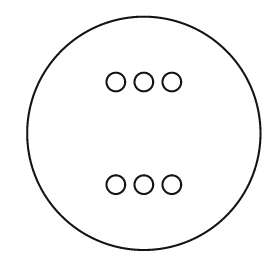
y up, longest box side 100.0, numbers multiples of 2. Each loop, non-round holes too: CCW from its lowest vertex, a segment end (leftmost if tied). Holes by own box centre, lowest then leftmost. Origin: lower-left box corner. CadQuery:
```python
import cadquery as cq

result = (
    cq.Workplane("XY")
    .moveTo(50.0, 50.0)
    .circle(50.0)
    .moveTo(38.0, 28.0)
    .circle(4.0)
    .moveTo(50.0, 28.0)
    .circle(4.0)
    .moveTo(62.0, 28.0)
    .circle(4.0)
    .moveTo(38.0, 72.0)
    .circle(4.0)
    .moveTo(50.0, 72.0)
    .circle(4.0)
    .moveTo(62.0, 72.0)
    .circle(4.0)
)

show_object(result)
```